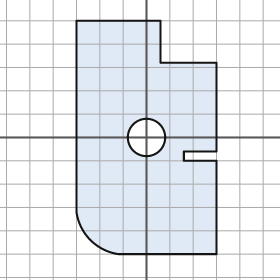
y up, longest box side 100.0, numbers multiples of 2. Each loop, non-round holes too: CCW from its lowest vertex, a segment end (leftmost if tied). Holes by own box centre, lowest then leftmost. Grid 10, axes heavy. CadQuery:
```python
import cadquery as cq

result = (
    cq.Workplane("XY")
    .moveTo(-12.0, -50.0)
    .lineTo(30.0, -50.0)
    .lineTo(30.0, -10.0)
    .lineTo(16.0, -10.0)
    .lineTo(16.0, -6.0)
    .lineTo(30.0, -6.0)
    .lineTo(30.0, 32.0)
    .lineTo(6.0, 32.0)
    .lineTo(6.0, 50.0)
    .lineTo(-30.0, 50.0)
    .lineTo(-30.0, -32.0)
    .threePointArc((-24.0, -44.0), (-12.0, -50.0))
    .close()
    .moveTo(0.0, 0.0)
    .circle(8.0)
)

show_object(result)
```